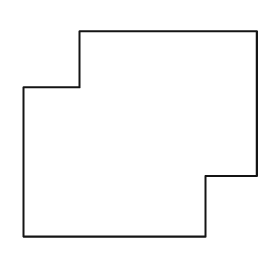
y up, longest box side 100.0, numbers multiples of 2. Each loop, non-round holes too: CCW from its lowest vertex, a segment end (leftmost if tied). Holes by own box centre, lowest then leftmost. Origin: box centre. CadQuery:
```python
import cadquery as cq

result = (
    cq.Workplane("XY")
    .moveTo(-50.0, -44.0)
    .lineTo(28.0, -44.0)
    .lineTo(28.0, -18.0)
    .lineTo(50.0, -18.0)
    .lineTo(50.0, 44.0)
    .lineTo(-26.0, 44.0)
    .lineTo(-26.0, 20.0)
    .lineTo(-50.0, 20.0)
    .close()
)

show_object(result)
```